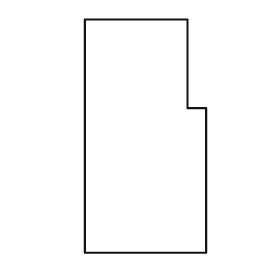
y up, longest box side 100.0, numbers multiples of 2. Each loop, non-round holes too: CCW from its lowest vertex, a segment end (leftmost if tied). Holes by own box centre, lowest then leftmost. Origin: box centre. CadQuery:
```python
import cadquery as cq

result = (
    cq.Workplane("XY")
    .moveTo(-26.0, -50.0)
    .lineTo(26.0, -50.0)
    .lineTo(26.0, 12.0)
    .lineTo(18.0, 12.0)
    .lineTo(18.0, 50.0)
    .lineTo(-26.0, 50.0)
    .close()
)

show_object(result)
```